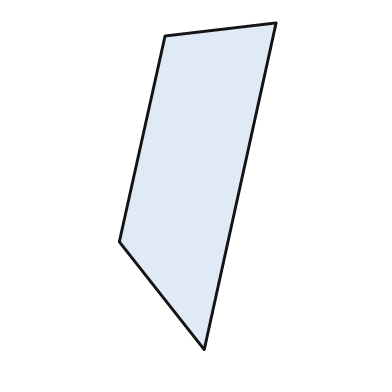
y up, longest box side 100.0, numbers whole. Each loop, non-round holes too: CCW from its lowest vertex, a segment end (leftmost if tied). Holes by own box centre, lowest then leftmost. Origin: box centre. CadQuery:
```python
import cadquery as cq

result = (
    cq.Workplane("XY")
    .moveTo(2.0, -50.0)
    .lineTo(24.0, 50.0)
    .lineTo(-10.0, 46.0)
    .lineTo(-24.0, -17.0)
    .close()
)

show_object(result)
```